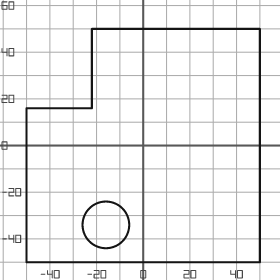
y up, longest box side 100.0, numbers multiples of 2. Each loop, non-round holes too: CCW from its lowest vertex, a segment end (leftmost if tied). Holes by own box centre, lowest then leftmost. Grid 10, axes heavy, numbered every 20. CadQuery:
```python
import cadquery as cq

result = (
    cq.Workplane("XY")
    .moveTo(-50.0, -50.0)
    .lineTo(50.0, -50.0)
    .lineTo(50.0, 50.0)
    .lineTo(-22.0, 50.0)
    .lineTo(-22.0, 16.0)
    .lineTo(-50.0, 16.0)
    .close()
    .moveTo(-16.0, -34.0)
    .circle(10.0)
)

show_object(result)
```